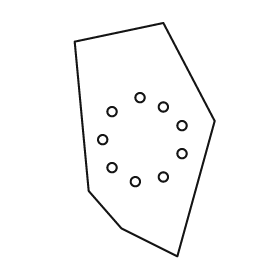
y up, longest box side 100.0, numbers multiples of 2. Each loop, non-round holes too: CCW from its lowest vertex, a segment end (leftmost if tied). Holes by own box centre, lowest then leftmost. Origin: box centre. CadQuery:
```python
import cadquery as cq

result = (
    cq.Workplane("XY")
    .moveTo(14.0, -50.0)
    .lineTo(30.0, 8.0)
    .lineTo(8.0, 50.0)
    .lineTo(-30.0, 42.0)
    .lineTo(-24.0, -22.0)
    .lineTo(-10.0, -38.0)
    .close()
    .moveTo(-4.0, -18.0)
    .circle(2.0)
    .moveTo(8.0, -16.0)
    .circle(2.0)
    .moveTo(-14.0, -12.0)
    .circle(2.0)
    .moveTo(16.0, -6.0)
    .circle(2.0)
    .moveTo(-18.0, 0.0)
    .circle(2.0)
    .moveTo(16.0, 6.0)
    .circle(2.0)
    .moveTo(-14.0, 12.0)
    .circle(2.0)
    .moveTo(8.0, 14.0)
    .circle(2.0)
    .moveTo(-2.0, 18.0)
    .circle(2.0)
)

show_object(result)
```